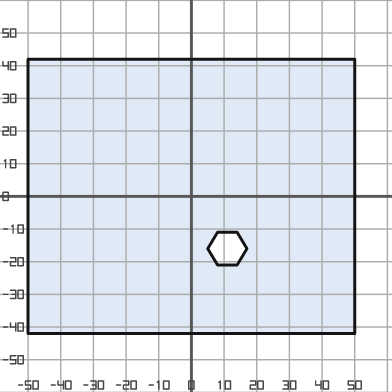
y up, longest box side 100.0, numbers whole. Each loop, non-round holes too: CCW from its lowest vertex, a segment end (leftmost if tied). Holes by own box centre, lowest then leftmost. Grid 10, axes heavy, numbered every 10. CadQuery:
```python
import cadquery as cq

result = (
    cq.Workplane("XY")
    .moveTo(-50.0, -42.0)
    .lineTo(50.0, -42.0)
    .lineTo(50.0, 42.0)
    .lineTo(-50.0, 42.0)
    .close()
    .moveTo(8.0, -21.0)
    .lineTo(14.0, -21.0)
    .lineTo(17.0, -16.0)
    .lineTo(14.0, -11.0)
    .lineTo(8.0, -11.0)
    .lineTo(5.0, -16.0)
    .close()
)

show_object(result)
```